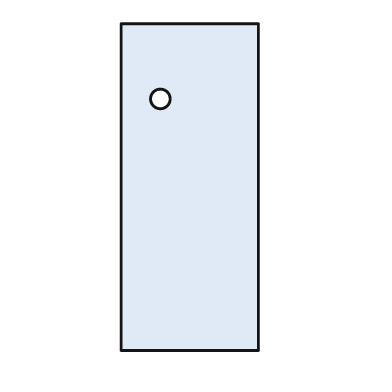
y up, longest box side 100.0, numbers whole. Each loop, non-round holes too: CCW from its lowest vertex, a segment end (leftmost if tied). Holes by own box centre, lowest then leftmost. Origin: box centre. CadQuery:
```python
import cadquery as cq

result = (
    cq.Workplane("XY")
    .moveTo(-21.0, -50.0)
    .lineTo(21.0, -50.0)
    .lineTo(21.0, 50.0)
    .lineTo(-21.0, 50.0)
    .close()
    .moveTo(-9.0, 27.0)
    .circle(3.0)
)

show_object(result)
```